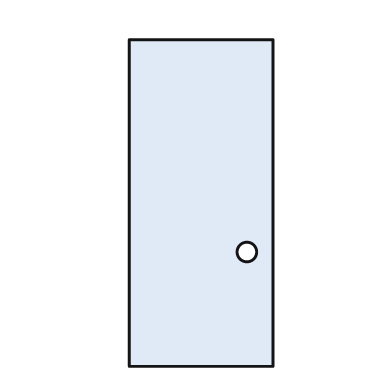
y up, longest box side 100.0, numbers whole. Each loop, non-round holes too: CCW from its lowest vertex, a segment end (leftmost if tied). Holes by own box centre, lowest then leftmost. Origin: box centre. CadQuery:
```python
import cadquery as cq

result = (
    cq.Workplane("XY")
    .moveTo(-22.0, -50.0)
    .lineTo(22.0, -50.0)
    .lineTo(22.0, 50.0)
    .lineTo(-22.0, 50.0)
    .close()
    .moveTo(14.0, -15.0)
    .circle(3.0)
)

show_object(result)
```